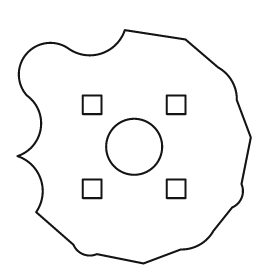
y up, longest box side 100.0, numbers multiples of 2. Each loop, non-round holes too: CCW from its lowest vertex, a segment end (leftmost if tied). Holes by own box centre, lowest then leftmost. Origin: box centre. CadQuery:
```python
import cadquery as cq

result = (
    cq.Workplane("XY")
    .moveTo(4.0, -50.0)
    .lineTo(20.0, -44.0)
    .threePointArc((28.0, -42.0), (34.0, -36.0))
    .lineTo(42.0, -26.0)
    .threePointArc((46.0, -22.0), (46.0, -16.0))
    .lineTo(50.0, 4.0)
    .lineTo(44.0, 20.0)
    .threePointArc((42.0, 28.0), (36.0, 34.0))
    .lineTo(22.0, 46.0)
    .lineTo(-4.0, 50.0)
    .threePointArc((-14.0, 40.0), (-28.0, 42.0))
    .threePointArc((-46.0, 40.0), (-46.0, 22.0))
    .threePointArc((-40.0, 8.0), (-50.0, -4.0))
    .threePointArc((-40.0, -14.0), (-42.0, -28.0))
    .lineTo(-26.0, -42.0)
    .threePointArc((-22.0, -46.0), (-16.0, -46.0))
    .close()
    .moveTo(-22.0, -22.0)
    .lineTo(-14.0, -22.0)
    .lineTo(-14.0, -14.0)
    .lineTo(-22.0, -14.0)
    .close()
    .moveTo(14.0, -22.0)
    .lineTo(22.0, -22.0)
    .lineTo(22.0, -14.0)
    .lineTo(14.0, -14.0)
    .close()
    .moveTo(0.0, 0.0)
    .circle(12.0)
    .moveTo(-22.0, 14.0)
    .lineTo(-14.0, 14.0)
    .lineTo(-14.0, 22.0)
    .lineTo(-22.0, 22.0)
    .close()
    .moveTo(14.0, 14.0)
    .lineTo(22.0, 14.0)
    .lineTo(22.0, 22.0)
    .lineTo(14.0, 22.0)
    .close()
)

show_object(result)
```